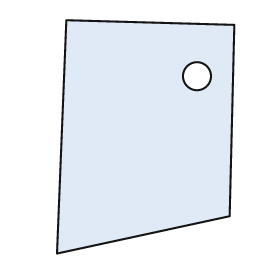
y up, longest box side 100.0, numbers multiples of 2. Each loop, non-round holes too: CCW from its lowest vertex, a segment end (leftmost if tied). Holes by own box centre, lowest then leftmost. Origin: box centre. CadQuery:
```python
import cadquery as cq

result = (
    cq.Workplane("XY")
    .moveTo(-38.0, -50.0)
    .lineTo(36.0, -34.0)
    .lineTo(38.0, 48.0)
    .lineTo(-34.0, 50.0)
    .close()
    .moveTo(22.0, 26.0)
    .circle(6.0)
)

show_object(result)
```